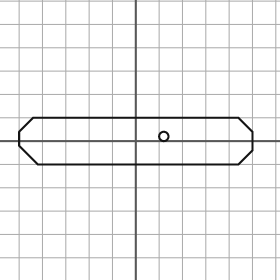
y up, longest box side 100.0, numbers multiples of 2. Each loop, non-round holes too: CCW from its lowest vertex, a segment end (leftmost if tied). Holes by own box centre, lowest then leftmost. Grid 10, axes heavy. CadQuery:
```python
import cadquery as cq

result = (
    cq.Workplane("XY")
    .moveTo(-42.0, -10.0)
    .lineTo(44.0, -10.0)
    .lineTo(50.0, -4.0)
    .lineTo(50.0, 4.0)
    .lineTo(44.0, 10.0)
    .lineTo(-44.0, 10.0)
    .lineTo(-50.0, 4.0)
    .lineTo(-50.0, -2.0)
    .close()
    .moveTo(12.0, 2.0)
    .circle(2.0)
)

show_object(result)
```